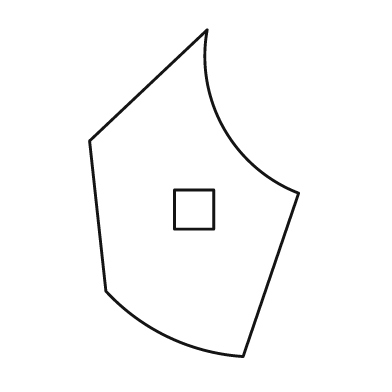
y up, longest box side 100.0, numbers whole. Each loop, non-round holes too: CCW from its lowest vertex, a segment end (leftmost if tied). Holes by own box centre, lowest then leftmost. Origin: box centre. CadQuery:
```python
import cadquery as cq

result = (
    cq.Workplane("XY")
    .moveTo(15.0, -50.0)
    .lineTo(32.0, 0.0)
    .threePointArc((9.0, 20.0), (4.0, 50.0))
    .lineTo(-32.0, 16.0)
    .lineTo(-27.0, -30.0)
    .threePointArc((-8.0, -44.0), (15.0, -50.0))
    .close()
    .moveTo(-6.0, -11.0)
    .lineTo(6.0, -11.0)
    .lineTo(6.0, 1.0)
    .lineTo(-6.0, 1.0)
    .close()
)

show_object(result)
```